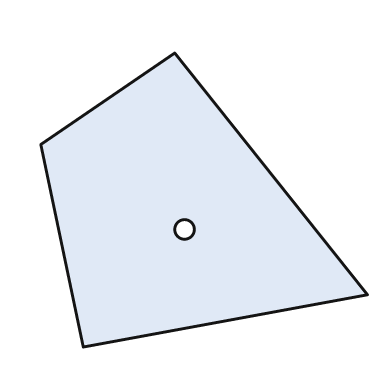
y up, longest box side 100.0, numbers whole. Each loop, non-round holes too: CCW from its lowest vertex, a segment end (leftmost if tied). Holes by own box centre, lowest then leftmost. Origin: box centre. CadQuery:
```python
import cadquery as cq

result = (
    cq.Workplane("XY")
    .moveTo(-37.0, -45.0)
    .lineTo(50.0, -29.0)
    .lineTo(-9.0, 45.0)
    .lineTo(-50.0, 17.0)
    .close()
    .moveTo(-6.0, -9.0)
    .circle(3.0)
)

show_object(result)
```